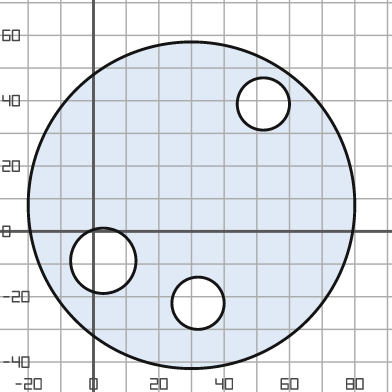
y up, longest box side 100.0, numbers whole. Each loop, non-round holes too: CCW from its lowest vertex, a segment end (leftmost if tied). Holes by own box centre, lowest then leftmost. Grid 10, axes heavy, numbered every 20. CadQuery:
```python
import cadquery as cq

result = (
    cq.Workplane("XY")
    .moveTo(30.0, 8.0)
    .circle(50.0)
    .moveTo(32.0, -22.0)
    .circle(8.0)
    .moveTo(3.0, -9.0)
    .circle(10.0)
    .moveTo(52.0, 39.0)
    .circle(8.0)
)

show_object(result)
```